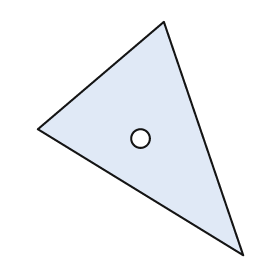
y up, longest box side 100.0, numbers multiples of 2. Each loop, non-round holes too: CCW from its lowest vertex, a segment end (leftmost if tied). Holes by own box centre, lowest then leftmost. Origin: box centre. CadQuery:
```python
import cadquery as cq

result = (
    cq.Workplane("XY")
    .moveTo(44.0, -50.0)
    .lineTo(10.0, 50.0)
    .lineTo(-44.0, 4.0)
    .close()
    .moveTo(0.0, 0.0)
    .circle(4.0)
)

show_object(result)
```